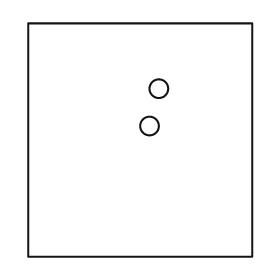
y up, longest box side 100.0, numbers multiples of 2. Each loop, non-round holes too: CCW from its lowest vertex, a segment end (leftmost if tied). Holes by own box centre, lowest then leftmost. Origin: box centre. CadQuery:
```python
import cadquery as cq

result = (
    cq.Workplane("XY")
    .moveTo(-48.0, -50.0)
    .lineTo(48.0, -50.0)
    .lineTo(48.0, 50.0)
    .lineTo(-48.0, 50.0)
    .close()
    .moveTo(4.0, 6.0)
    .circle(4.0)
    .moveTo(8.0, 22.0)
    .circle(4.0)
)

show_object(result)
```